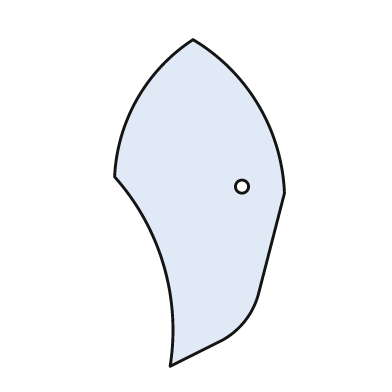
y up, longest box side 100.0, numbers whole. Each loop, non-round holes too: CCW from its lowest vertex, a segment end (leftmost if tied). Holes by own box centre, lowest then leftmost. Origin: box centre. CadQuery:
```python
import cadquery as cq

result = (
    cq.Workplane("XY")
    .moveTo(-9.0, -50.0)
    .lineTo(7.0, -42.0)
    .threePointArc((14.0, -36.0), (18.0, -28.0))
    .lineTo(26.0, 3.0)
    .threePointArc((18.0, 30.0), (-2.0, 50.0))
    .threePointArc((-19.0, 32.0), (-26.0, 8.0))
    .threePointArc((-11.0, -19.0), (-9.0, -50.0))
    .close()
    .moveTo(13.0, 5.0)
    .circle(2.0)
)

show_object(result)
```